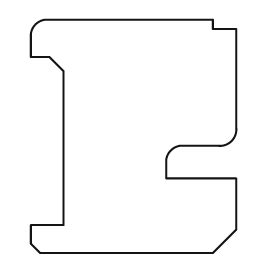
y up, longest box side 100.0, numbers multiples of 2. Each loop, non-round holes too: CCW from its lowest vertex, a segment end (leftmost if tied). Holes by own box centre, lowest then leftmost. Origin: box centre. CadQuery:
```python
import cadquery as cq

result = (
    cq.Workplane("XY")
    .moveTo(-40.0, -50.0)
    .lineTo(34.0, -50.0)
    .lineTo(44.0, -40.0)
    .lineTo(44.0, -18.0)
    .lineTo(14.0, -18.0)
    .lineTo(14.0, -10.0)
    .threePointArc((16.0, -6.0), (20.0, -4.0))
    .lineTo(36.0, -4.0)
    .threePointArc((42.0, -2.0), (44.0, 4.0))
    .lineTo(44.0, 46.0)
    .lineTo(34.0, 46.0)
    .lineTo(34.0, 50.0)
    .lineTo(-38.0, 50.0)
    .threePointArc((-42.0, 48.0), (-44.0, 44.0))
    .lineTo(-44.0, 34.0)
    .lineTo(-36.0, 34.0)
    .lineTo(-30.0, 28.0)
    .lineTo(-30.0, -38.0)
    .lineTo(-44.0, -38.0)
    .lineTo(-44.0, -46.0)
    .close()
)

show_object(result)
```